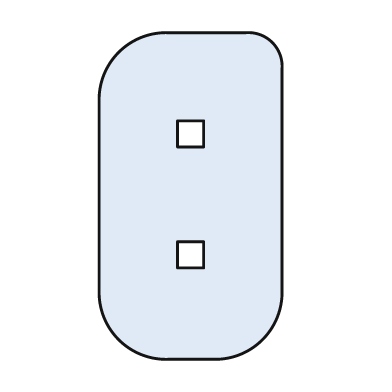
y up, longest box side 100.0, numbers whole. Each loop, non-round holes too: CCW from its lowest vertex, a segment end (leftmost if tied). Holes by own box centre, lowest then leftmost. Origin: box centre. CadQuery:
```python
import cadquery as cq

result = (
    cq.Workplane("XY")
    .moveTo(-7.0, -50.0)
    .lineTo(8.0, -50.0)
    .threePointArc((22.0, -44.0), (28.0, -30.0))
    .lineTo(28.0, 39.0)
    .threePointArc((25.0, 47.0), (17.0, 50.0))
    .lineTo(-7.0, 50.0)
    .threePointArc((-22.0, 44.0), (-28.0, 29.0))
    .lineTo(-28.0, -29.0)
    .threePointArc((-22.0, -44.0), (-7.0, -50.0))
    .close()
    .moveTo(-4.0, -22.0)
    .lineTo(4.0, -22.0)
    .lineTo(4.0, -14.0)
    .lineTo(-4.0, -14.0)
    .close()
    .moveTo(-4.0, 15.0)
    .lineTo(4.0, 15.0)
    .lineTo(4.0, 23.0)
    .lineTo(-4.0, 23.0)
    .close()
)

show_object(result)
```